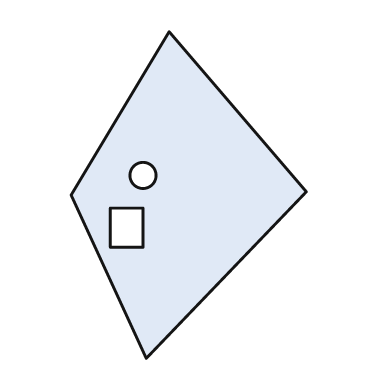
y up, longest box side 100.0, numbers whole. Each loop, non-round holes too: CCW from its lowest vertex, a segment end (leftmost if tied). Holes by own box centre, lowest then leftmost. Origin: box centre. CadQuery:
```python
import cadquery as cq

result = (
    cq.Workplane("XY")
    .moveTo(-13.0, -50.0)
    .lineTo(36.0, 1.0)
    .lineTo(-6.0, 50.0)
    .lineTo(-36.0, 0.0)
    .close()
    .moveTo(-24.0, -16.0)
    .lineTo(-14.0, -16.0)
    .lineTo(-14.0, -4.0)
    .lineTo(-24.0, -4.0)
    .close()
    .moveTo(-14.0, 6.0)
    .circle(4.0)
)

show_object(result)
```